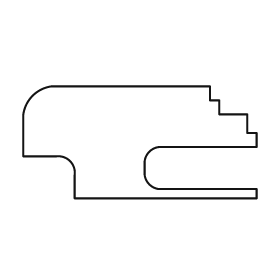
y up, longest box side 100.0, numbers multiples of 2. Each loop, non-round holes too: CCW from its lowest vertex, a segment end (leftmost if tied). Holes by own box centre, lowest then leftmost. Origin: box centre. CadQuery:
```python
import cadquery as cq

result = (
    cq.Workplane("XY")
    .moveTo(-28.0, -24.0)
    .lineTo(50.0, -24.0)
    .lineTo(50.0, -20.0)
    .lineTo(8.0, -20.0)
    .threePointArc((4.0, -18.0), (2.0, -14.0))
    .lineTo(2.0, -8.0)
    .threePointArc((4.0, -4.0), (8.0, -2.0))
    .lineTo(50.0, -2.0)
    .lineTo(50.0, 4.0)
    .lineTo(46.0, 4.0)
    .lineTo(46.0, 12.0)
    .lineTo(34.0, 12.0)
    .lineTo(34.0, 18.0)
    .lineTo(30.0, 18.0)
    .lineTo(30.0, 24.0)
    .lineTo(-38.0, 24.0)
    .threePointArc((-46.0, 20.0), (-50.0, 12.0))
    .lineTo(-50.0, -6.0)
    .lineTo(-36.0, -6.0)
    .threePointArc((-30.0, -8.0), (-28.0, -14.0))
    .close()
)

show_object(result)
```